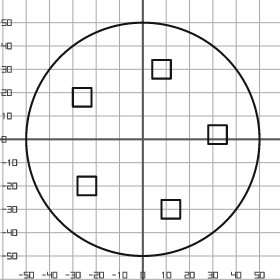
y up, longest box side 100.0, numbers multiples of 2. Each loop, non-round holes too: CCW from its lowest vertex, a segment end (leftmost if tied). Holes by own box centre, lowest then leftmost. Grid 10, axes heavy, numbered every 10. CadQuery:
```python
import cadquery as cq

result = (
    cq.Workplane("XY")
    .moveTo(0.0, 0.0)
    .circle(50.0)
    .moveTo(8.0, -34.0)
    .lineTo(16.0, -34.0)
    .lineTo(16.0, -26.0)
    .lineTo(8.0, -26.0)
    .close()
    .moveTo(-28.0, -24.0)
    .lineTo(-20.0, -24.0)
    .lineTo(-20.0, -16.0)
    .lineTo(-28.0, -16.0)
    .close()
    .moveTo(28.0, -2.0)
    .lineTo(36.0, -2.0)
    .lineTo(36.0, 6.0)
    .lineTo(28.0, 6.0)
    .close()
    .moveTo(-30.0, 14.0)
    .lineTo(-22.0, 14.0)
    .lineTo(-22.0, 22.0)
    .lineTo(-30.0, 22.0)
    .close()
    .moveTo(4.0, 26.0)
    .lineTo(12.0, 26.0)
    .lineTo(12.0, 34.0)
    .lineTo(4.0, 34.0)
    .close()
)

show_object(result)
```